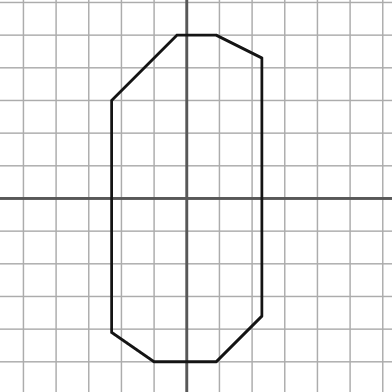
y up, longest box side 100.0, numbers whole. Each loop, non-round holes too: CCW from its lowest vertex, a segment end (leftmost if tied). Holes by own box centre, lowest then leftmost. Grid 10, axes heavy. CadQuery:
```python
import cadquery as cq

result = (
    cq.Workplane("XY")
    .moveTo(-10.0, -50.0)
    .lineTo(9.0, -50.0)
    .lineTo(23.0, -36.0)
    .lineTo(23.0, 43.0)
    .lineTo(9.0, 50.0)
    .lineTo(-3.0, 50.0)
    .lineTo(-23.0, 30.0)
    .lineTo(-23.0, -41.0)
    .close()
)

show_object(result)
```